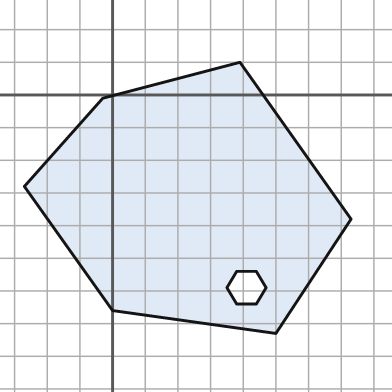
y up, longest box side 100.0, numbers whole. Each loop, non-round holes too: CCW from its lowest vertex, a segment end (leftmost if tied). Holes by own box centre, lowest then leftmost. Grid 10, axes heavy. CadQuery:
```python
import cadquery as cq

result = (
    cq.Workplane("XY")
    .moveTo(50.0, -73.0)
    .lineTo(73.0, -38.0)
    .lineTo(39.0, 10.0)
    .lineTo(-3.0, -1.0)
    .lineTo(-27.0, -28.0)
    .lineTo(0.0, -66.0)
    .close()
    .moveTo(38.0, -64.0)
    .lineTo(44.0, -64.0)
    .lineTo(47.0, -59.0)
    .lineTo(44.0, -54.0)
    .lineTo(38.0, -54.0)
    .lineTo(35.0, -59.0)
    .close()
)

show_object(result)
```